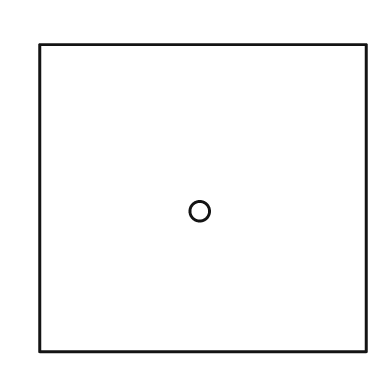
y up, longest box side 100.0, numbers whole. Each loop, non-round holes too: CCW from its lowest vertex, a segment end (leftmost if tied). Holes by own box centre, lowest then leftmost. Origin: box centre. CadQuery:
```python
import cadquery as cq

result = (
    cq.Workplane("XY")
    .moveTo(-50.0, -47.0)
    .lineTo(50.0, -47.0)
    .lineTo(50.0, 47.0)
    .lineTo(-50.0, 47.0)
    .close()
    .moveTo(-1.0, -4.0)
    .circle(3.0)
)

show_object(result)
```